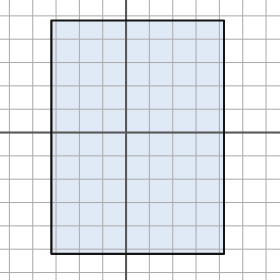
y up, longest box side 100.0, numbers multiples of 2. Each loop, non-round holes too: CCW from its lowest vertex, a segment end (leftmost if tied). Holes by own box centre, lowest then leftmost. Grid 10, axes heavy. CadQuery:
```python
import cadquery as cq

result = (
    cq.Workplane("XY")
    .moveTo(-32.0, -52.0)
    .lineTo(42.0, -52.0)
    .lineTo(42.0, 48.0)
    .lineTo(-32.0, 48.0)
    .close()
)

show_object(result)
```